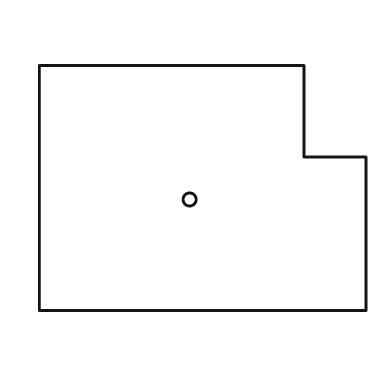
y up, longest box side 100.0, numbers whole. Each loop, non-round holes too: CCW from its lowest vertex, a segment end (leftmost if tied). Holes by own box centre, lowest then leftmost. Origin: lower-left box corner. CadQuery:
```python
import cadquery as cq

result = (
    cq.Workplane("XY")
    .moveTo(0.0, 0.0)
    .lineTo(100.0, 0.0)
    .lineTo(100.0, 47.0)
    .lineTo(81.0, 47.0)
    .lineTo(81.0, 75.0)
    .lineTo(0.0, 75.0)
    .close()
    .moveTo(46.0, 34.0)
    .circle(2.0)
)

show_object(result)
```